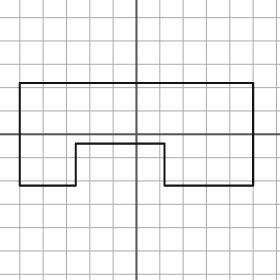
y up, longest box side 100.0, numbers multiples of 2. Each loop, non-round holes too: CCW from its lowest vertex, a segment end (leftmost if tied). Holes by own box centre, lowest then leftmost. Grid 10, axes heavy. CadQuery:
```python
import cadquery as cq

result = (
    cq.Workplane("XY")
    .moveTo(-50.0, -22.0)
    .lineTo(-26.0, -22.0)
    .lineTo(-26.0, -4.0)
    .lineTo(12.0, -4.0)
    .lineTo(12.0, -22.0)
    .lineTo(50.0, -22.0)
    .lineTo(50.0, 22.0)
    .lineTo(-50.0, 22.0)
    .close()
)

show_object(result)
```